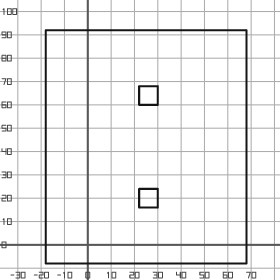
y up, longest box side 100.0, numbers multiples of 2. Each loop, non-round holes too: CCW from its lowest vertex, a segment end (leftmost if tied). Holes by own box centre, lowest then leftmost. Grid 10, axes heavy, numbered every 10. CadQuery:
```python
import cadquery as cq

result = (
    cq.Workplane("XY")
    .moveTo(-18.0, -8.0)
    .lineTo(68.0, -8.0)
    .lineTo(68.0, 92.0)
    .lineTo(-18.0, 92.0)
    .close()
    .moveTo(22.0, 16.0)
    .lineTo(30.0, 16.0)
    .lineTo(30.0, 24.0)
    .lineTo(22.0, 24.0)
    .close()
    .moveTo(22.0, 60.0)
    .lineTo(30.0, 60.0)
    .lineTo(30.0, 68.0)
    .lineTo(22.0, 68.0)
    .close()
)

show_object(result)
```